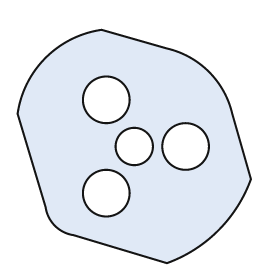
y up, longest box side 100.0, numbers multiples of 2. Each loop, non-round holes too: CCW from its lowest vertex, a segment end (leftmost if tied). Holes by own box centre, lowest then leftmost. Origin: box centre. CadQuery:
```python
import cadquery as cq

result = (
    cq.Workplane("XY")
    .moveTo(14.0, -50.0)
    .threePointArc((36.0, -36.0), (50.0, -14.0))
    .lineTo(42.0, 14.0)
    .threePointArc((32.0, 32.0), (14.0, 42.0))
    .lineTo(-14.0, 50.0)
    .threePointArc((-38.0, 38.0), (-50.0, 14.0))
    .lineTo(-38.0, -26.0)
    .threePointArc((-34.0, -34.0), (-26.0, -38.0))
    .close()
    .moveTo(-12.0, -20.0)
    .circle(10.0)
    .moveTo(0.0, 0.0)
    .circle(8.0)
    .moveTo(22.0, 0.0)
    .circle(10.0)
    .moveTo(-12.0, 20.0)
    .circle(10.0)
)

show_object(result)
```